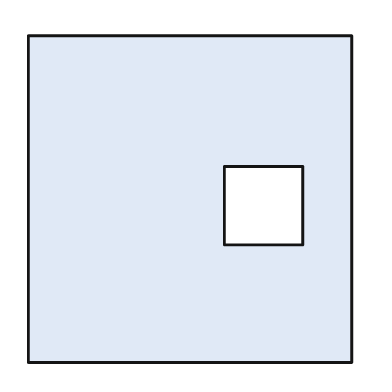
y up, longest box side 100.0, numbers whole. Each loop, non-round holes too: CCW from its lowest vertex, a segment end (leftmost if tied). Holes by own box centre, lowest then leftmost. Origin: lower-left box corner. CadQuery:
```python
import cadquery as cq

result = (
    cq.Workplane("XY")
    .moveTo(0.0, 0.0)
    .lineTo(99.0, 0.0)
    .lineTo(99.0, 100.0)
    .lineTo(0.0, 100.0)
    .close()
    .moveTo(60.0, 36.0)
    .lineTo(84.0, 36.0)
    .lineTo(84.0, 60.0)
    .lineTo(60.0, 60.0)
    .close()
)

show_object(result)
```